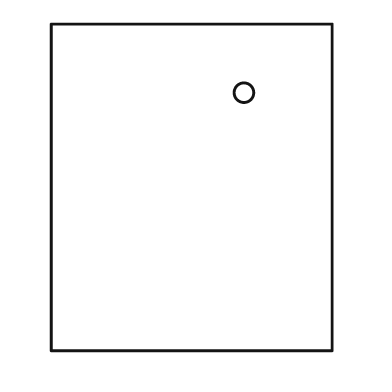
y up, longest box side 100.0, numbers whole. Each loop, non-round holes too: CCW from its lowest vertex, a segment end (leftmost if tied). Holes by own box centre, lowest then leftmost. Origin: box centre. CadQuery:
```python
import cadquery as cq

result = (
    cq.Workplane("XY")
    .moveTo(-43.0, -50.0)
    .lineTo(43.0, -50.0)
    .lineTo(43.0, 50.0)
    .lineTo(-43.0, 50.0)
    .close()
    .moveTo(16.0, 29.0)
    .circle(3.0)
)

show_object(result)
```